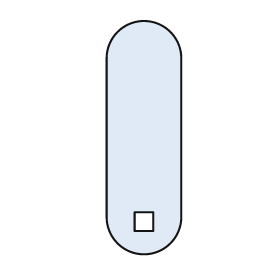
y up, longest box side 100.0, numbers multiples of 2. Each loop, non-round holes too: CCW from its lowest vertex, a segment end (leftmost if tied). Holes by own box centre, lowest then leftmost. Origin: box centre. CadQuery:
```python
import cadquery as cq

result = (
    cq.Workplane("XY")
    .moveTo(-16.0, -34.0)
    .threePointArc((0.0, -50.0), (16.0, -34.0))
    .lineTo(16.0, 34.0)
    .threePointArc((0.0, 50.0), (-16.0, 34.0))
    .close()
    .moveTo(-4.0, -40.0)
    .lineTo(4.0, -40.0)
    .lineTo(4.0, -32.0)
    .lineTo(-4.0, -32.0)
    .close()
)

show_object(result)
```